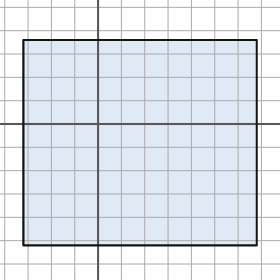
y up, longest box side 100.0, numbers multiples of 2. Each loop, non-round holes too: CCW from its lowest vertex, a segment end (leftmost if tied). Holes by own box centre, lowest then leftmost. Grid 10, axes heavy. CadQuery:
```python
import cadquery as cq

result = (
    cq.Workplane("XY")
    .moveTo(-32.0, -52.0)
    .lineTo(68.0, -52.0)
    .lineTo(68.0, 36.0)
    .lineTo(-32.0, 36.0)
    .close()
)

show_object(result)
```